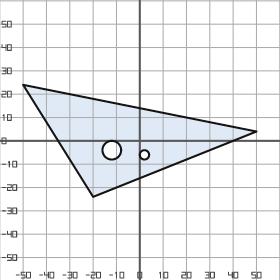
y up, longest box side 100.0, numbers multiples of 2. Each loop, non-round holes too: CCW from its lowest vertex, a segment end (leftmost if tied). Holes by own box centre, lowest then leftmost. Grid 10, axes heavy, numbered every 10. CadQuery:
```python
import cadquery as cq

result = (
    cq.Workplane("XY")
    .moveTo(-20.0, -24.0)
    .lineTo(50.0, 4.0)
    .lineTo(-50.0, 24.0)
    .close()
    .moveTo(2.0, -6.0)
    .circle(2.0)
    .moveTo(-12.0, -4.0)
    .circle(4.0)
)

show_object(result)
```